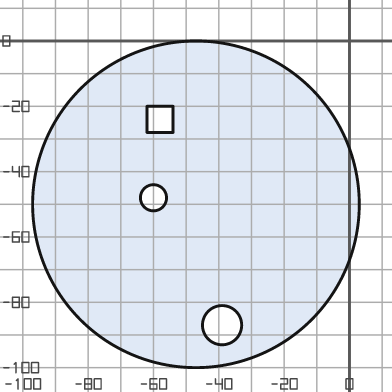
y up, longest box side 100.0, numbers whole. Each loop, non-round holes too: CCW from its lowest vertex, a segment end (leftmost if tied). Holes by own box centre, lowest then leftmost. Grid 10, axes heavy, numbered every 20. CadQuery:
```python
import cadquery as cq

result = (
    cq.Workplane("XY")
    .moveTo(-47.0, -50.0)
    .circle(50.0)
    .moveTo(-39.0, -87.0)
    .circle(6.0)
    .moveTo(-60.0, -48.0)
    .circle(4.0)
    .moveTo(-62.0, -28.0)
    .lineTo(-54.0, -28.0)
    .lineTo(-54.0, -20.0)
    .lineTo(-62.0, -20.0)
    .close()
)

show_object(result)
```